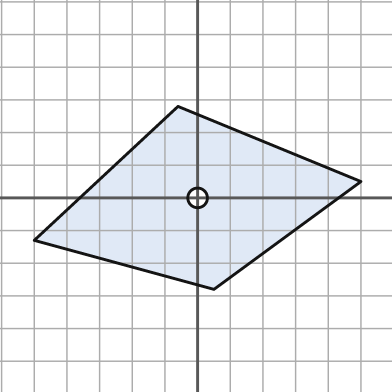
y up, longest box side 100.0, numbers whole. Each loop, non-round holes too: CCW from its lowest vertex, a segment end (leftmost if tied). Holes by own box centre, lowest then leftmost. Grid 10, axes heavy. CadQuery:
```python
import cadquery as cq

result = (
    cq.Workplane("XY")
    .moveTo(5.0, -28.0)
    .lineTo(50.0, 5.0)
    .lineTo(-6.0, 28.0)
    .lineTo(-50.0, -13.0)
    .close()
    .moveTo(0.0, 0.0)
    .circle(3.0)
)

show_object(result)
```